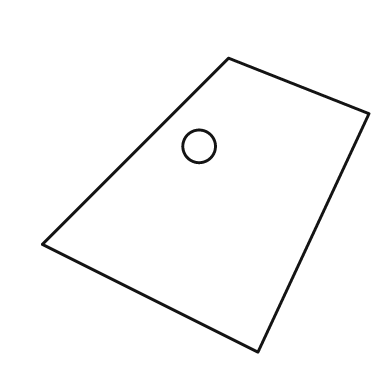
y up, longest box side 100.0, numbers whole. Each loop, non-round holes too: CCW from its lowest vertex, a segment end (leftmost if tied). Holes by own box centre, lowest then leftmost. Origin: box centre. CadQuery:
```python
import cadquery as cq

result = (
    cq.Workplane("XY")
    .moveTo(16.0, -45.0)
    .lineTo(50.0, 28.0)
    .lineTo(7.0, 45.0)
    .lineTo(-50.0, -12.0)
    .close()
    .moveTo(-2.0, 18.0)
    .circle(5.0)
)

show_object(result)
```